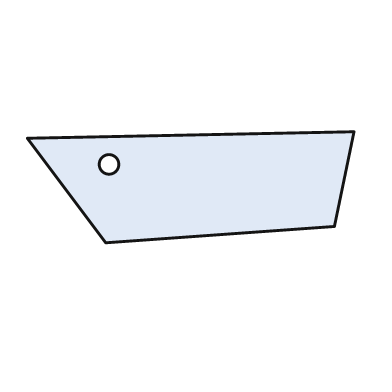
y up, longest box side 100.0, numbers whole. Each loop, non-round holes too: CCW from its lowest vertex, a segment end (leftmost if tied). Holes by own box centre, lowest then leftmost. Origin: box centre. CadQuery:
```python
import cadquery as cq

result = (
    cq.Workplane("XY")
    .moveTo(-26.0, -17.0)
    .lineTo(44.0, -12.0)
    .lineTo(50.0, 17.0)
    .lineTo(-50.0, 15.0)
    .close()
    .moveTo(-25.0, 7.0)
    .circle(3.0)
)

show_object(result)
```